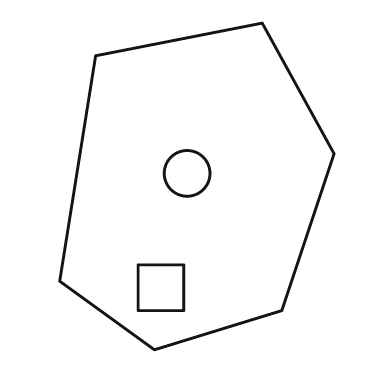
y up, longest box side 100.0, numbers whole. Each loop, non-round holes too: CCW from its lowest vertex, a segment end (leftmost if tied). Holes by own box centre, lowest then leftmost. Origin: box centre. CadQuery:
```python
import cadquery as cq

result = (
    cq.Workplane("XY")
    .moveTo(-13.0, -50.0)
    .lineTo(26.0, -38.0)
    .lineTo(42.0, 10.0)
    .lineTo(20.0, 50.0)
    .lineTo(-31.0, 40.0)
    .lineTo(-42.0, -29.0)
    .close()
    .moveTo(-18.0, -38.0)
    .lineTo(-4.0, -38.0)
    .lineTo(-4.0, -24.0)
    .lineTo(-18.0, -24.0)
    .close()
    .moveTo(-3.0, 4.0)
    .circle(7.0)
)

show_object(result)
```